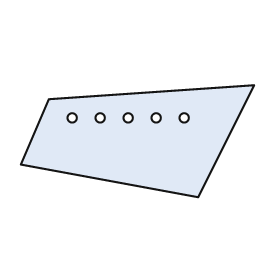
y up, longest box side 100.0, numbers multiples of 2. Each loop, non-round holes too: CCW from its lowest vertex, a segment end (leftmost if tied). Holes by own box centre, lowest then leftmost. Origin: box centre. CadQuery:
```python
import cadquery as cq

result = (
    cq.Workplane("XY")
    .moveTo(26.0, -24.0)
    .lineTo(50.0, 24.0)
    .lineTo(-38.0, 18.0)
    .lineTo(-50.0, -10.0)
    .close()
    .moveTo(-28.0, 10.0)
    .circle(2.0)
    .moveTo(-16.0, 10.0)
    .circle(2.0)
    .moveTo(-4.0, 10.0)
    .circle(2.0)
    .moveTo(8.0, 10.0)
    .circle(2.0)
    .moveTo(20.0, 10.0)
    .circle(2.0)
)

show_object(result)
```